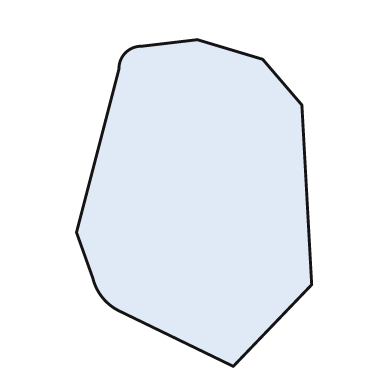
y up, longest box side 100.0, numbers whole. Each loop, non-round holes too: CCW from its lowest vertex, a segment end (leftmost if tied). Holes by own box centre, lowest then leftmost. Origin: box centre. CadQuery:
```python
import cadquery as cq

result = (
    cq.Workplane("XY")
    .moveTo(12.0, -50.0)
    .lineTo(36.0, -25.0)
    .lineTo(33.0, 30.0)
    .lineTo(21.0, 44.0)
    .lineTo(1.0, 50.0)
    .lineTo(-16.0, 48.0)
    .threePointArc((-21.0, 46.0), (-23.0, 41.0))
    .lineTo(-36.0, -9.0)
    .lineTo(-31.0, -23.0)
    .threePointArc((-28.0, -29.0), (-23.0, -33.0))
    .close()
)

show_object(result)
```